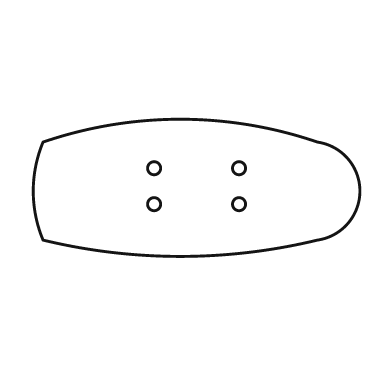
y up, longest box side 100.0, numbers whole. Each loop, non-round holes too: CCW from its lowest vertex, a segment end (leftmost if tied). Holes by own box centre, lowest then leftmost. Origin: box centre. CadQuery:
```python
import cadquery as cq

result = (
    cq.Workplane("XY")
    .moveTo(-47.0, -16.0)
    .threePointArc((-5.0, -21.0), (37.0, -16.0))
    .threePointArc((50.0, -1.0), (37.0, 14.0))
    .threePointArc((-5.0, 21.0), (-47.0, 14.0))
    .threePointArc((-50.0, -1.0), (-47.0, -16.0))
    .close()
    .moveTo(-13.0, -5.0)
    .circle(2.0)
    .moveTo(13.0, -5.0)
    .circle(2.0)
    .moveTo(-13.0, 6.0)
    .circle(2.0)
    .moveTo(13.0, 6.0)
    .circle(2.0)
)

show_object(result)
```